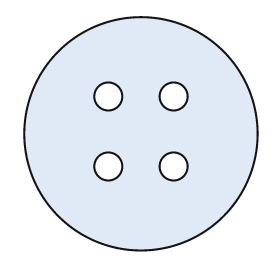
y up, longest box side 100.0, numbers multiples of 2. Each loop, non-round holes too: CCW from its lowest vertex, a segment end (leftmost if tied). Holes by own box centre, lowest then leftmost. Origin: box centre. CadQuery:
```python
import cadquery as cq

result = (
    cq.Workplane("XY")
    .moveTo(0.0, 0.0)
    .circle(50.0)
    .moveTo(-14.0, -14.0)
    .circle(6.0)
    .moveTo(14.0, -14.0)
    .circle(6.0)
    .moveTo(-14.0, 16.0)
    .circle(6.0)
    .moveTo(14.0, 16.0)
    .circle(6.0)
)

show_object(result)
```